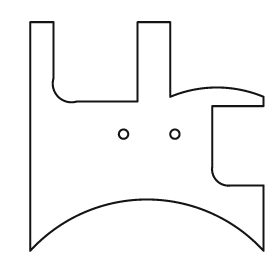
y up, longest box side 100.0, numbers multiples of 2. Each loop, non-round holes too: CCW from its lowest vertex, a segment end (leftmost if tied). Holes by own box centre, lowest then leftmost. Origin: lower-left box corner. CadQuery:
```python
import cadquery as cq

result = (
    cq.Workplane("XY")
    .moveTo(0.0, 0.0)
    .threePointArc((50.0, 22.0), (100.0, 0.0))
    .lineTo(100.0, 28.0)
    .lineTo(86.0, 28.0)
    .threePointArc((80.0, 30.0), (78.0, 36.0))
    .lineTo(78.0, 62.0)
    .lineTo(100.0, 62.0)
    .lineTo(100.0, 66.0)
    .threePointArc((80.0, 70.0), (60.0, 66.0))
    .lineTo(60.0, 98.0)
    .lineTo(46.0, 98.0)
    .lineTo(46.0, 64.0)
    .lineTo(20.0, 64.0)
    .threePointArc((12.0, 66.0), (10.0, 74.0))
    .lineTo(10.0, 98.0)
    .lineTo(0.0, 98.0)
    .close()
    .moveTo(40.0, 50.0)
    .circle(2.0)
    .moveTo(62.0, 50.0)
    .circle(2.0)
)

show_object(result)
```